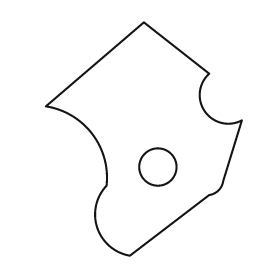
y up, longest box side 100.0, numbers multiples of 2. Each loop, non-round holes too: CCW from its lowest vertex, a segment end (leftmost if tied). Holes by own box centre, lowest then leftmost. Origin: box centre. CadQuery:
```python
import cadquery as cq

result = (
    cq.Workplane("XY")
    .moveTo(-6.0, -50.0)
    .lineTo(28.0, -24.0)
    .threePointArc((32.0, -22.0), (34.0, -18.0))
    .lineTo(42.0, 8.0)
    .threePointArc((26.0, 12.0), (28.0, 28.0))
    .lineTo(0.0, 50.0)
    .lineTo(-42.0, 14.0)
    .threePointArc((-22.0, 2.0), (-16.0, -20.0))
    .threePointArc((-20.0, -38.0), (-6.0, -50.0))
    .close()
    .moveTo(6.0, -12.0)
    .circle(8.0)
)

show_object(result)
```